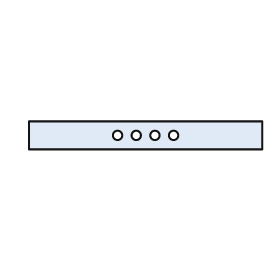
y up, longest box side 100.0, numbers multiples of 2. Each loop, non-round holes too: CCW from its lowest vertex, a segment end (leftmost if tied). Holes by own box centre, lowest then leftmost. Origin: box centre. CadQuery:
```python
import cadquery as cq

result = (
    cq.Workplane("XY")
    .moveTo(-50.0, -6.0)
    .lineTo(50.0, -6.0)
    .lineTo(50.0, 6.0)
    .lineTo(-50.0, 6.0)
    .close()
    .moveTo(-12.0, 0.0)
    .circle(2.0)
    .moveTo(-4.0, 0.0)
    .circle(2.0)
    .moveTo(4.0, 0.0)
    .circle(2.0)
    .moveTo(12.0, 0.0)
    .circle(2.0)
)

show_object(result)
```